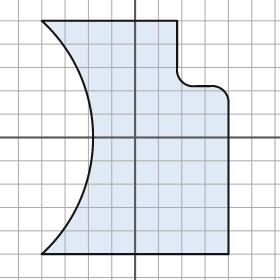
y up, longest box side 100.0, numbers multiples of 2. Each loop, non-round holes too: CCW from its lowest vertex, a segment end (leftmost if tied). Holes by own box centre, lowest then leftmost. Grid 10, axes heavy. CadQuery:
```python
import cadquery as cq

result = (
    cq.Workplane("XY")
    .moveTo(-40.0, -50.0)
    .lineTo(40.0, -50.0)
    .lineTo(40.0, 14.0)
    .threePointArc((38.0, 20.0), (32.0, 22.0))
    .lineTo(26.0, 22.0)
    .threePointArc((20.0, 24.0), (18.0, 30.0))
    .lineTo(18.0, 50.0)
    .lineTo(-40.0, 50.0)
    .threePointArc((-18.0, 0.0), (-40.0, -50.0))
    .close()
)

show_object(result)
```